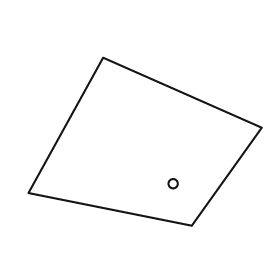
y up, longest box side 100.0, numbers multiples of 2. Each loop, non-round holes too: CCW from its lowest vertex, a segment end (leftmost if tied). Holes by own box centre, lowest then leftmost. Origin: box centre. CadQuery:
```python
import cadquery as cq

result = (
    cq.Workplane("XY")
    .moveTo(20.0, -36.0)
    .lineTo(50.0, 6.0)
    .lineTo(-18.0, 36.0)
    .lineTo(-50.0, -22.0)
    .close()
    .moveTo(12.0, -18.0)
    .circle(2.0)
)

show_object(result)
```